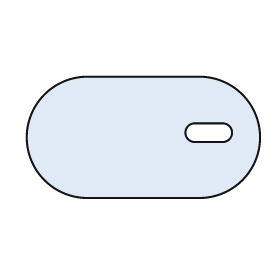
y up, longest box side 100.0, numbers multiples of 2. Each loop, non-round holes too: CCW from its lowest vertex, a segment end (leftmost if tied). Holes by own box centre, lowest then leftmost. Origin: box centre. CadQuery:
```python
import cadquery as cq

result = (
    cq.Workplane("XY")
    .moveTo(-24.0, -26.0)
    .lineTo(24.0, -26.0)
    .threePointArc((50.0, 0.0), (24.0, 26.0))
    .lineTo(-24.0, 26.0)
    .threePointArc((-50.0, 0.0), (-24.0, -26.0))
    .close()
    .moveTo(22.0, -2.0)
    .lineTo(34.0, -2.0)
    .threePointArc((38.0, 2.0), (34.0, 6.0))
    .lineTo(22.0, 6.0)
    .threePointArc((18.0, 2.0), (22.0, -2.0))
    .close()
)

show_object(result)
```